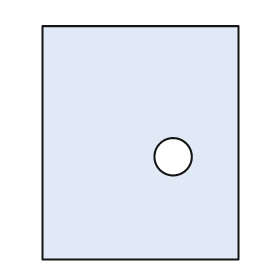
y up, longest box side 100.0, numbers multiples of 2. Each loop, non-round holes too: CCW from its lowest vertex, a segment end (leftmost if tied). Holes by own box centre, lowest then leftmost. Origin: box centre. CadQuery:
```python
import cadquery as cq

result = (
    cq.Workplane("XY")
    .moveTo(-42.0, -50.0)
    .lineTo(42.0, -50.0)
    .lineTo(42.0, 50.0)
    .lineTo(-42.0, 50.0)
    .close()
    .moveTo(14.0, -6.0)
    .circle(8.0)
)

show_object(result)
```